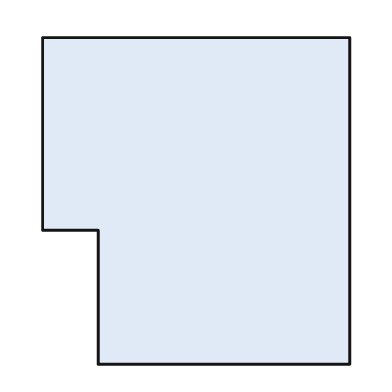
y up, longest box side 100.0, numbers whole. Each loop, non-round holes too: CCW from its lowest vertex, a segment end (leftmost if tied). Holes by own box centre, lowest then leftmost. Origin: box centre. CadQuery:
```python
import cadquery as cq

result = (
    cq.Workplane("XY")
    .moveTo(-30.0, -50.0)
    .lineTo(47.0, -50.0)
    .lineTo(47.0, 50.0)
    .lineTo(-47.0, 50.0)
    .lineTo(-47.0, -9.0)
    .lineTo(-30.0, -9.0)
    .close()
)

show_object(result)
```